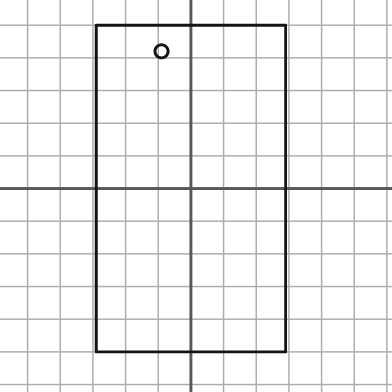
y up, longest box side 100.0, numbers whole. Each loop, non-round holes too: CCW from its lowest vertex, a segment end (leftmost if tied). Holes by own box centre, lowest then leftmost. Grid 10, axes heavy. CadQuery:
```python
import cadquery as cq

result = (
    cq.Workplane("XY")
    .moveTo(-29.0, -50.0)
    .lineTo(29.0, -50.0)
    .lineTo(29.0, 50.0)
    .lineTo(-29.0, 50.0)
    .close()
    .moveTo(-9.0, 42.0)
    .circle(2.0)
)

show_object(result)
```